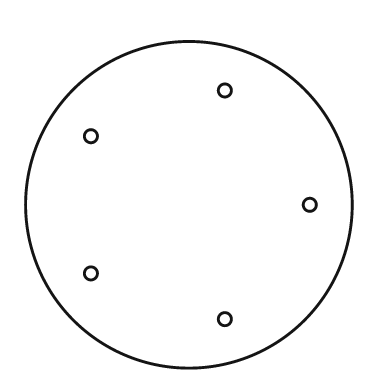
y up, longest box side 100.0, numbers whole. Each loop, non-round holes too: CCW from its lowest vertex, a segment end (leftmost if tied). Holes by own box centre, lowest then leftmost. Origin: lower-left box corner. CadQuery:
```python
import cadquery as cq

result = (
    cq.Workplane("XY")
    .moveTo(50.0, 50.0)
    .circle(50.0)
    .moveTo(61.0, 15.0)
    .circle(2.0)
    .moveTo(20.0, 29.0)
    .circle(2.0)
    .moveTo(87.0, 50.0)
    .circle(2.0)
    .moveTo(20.0, 71.0)
    .circle(2.0)
    .moveTo(61.0, 85.0)
    .circle(2.0)
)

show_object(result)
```